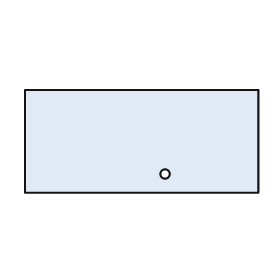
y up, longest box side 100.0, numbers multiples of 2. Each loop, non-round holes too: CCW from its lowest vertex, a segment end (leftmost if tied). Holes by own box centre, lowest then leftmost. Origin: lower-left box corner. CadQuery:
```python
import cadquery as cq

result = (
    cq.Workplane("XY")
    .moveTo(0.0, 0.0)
    .lineTo(100.0, 0.0)
    .lineTo(100.0, 44.0)
    .lineTo(0.0, 44.0)
    .close()
    .moveTo(60.0, 8.0)
    .circle(2.0)
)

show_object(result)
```